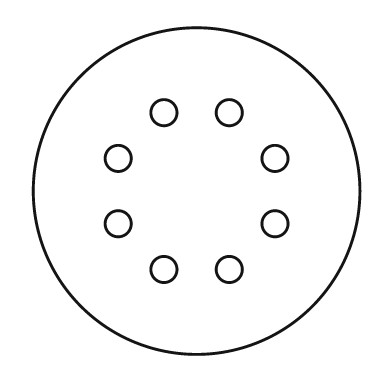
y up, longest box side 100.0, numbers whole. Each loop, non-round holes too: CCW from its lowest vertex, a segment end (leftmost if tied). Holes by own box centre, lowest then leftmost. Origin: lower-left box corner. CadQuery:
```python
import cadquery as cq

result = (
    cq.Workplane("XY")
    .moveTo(50.0, 50.0)
    .circle(50.0)
    .moveTo(40.0, 26.0)
    .circle(4.0)
    .moveTo(60.0, 26.0)
    .circle(4.0)
    .moveTo(26.0, 40.0)
    .circle(4.0)
    .moveTo(74.0, 40.0)
    .circle(4.0)
    .moveTo(26.0, 60.0)
    .circle(4.0)
    .moveTo(74.0, 60.0)
    .circle(4.0)
    .moveTo(40.0, 74.0)
    .circle(4.0)
    .moveTo(60.0, 74.0)
    .circle(4.0)
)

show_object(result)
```